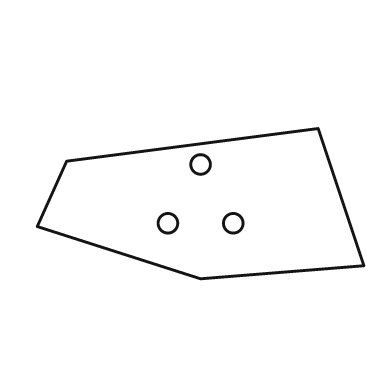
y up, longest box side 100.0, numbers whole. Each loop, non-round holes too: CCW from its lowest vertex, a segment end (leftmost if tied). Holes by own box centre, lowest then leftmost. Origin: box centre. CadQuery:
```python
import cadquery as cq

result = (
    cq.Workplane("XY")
    .moveTo(0.0, -23.0)
    .lineTo(50.0, -19.0)
    .lineTo(36.0, 23.0)
    .lineTo(-41.0, 13.0)
    .lineTo(-50.0, -7.0)
    .close()
    .moveTo(-10.0, -6.0)
    .circle(3.0)
    .moveTo(10.0, -6.0)
    .circle(3.0)
    .moveTo(0.0, 12.0)
    .circle(3.0)
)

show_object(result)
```